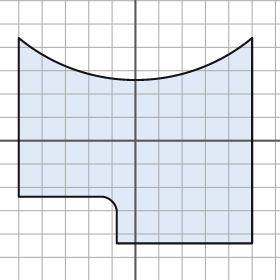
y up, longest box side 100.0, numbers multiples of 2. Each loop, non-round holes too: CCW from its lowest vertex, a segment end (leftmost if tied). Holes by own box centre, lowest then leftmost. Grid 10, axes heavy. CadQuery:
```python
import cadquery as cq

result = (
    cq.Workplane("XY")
    .moveTo(-8.0, -44.0)
    .lineTo(50.0, -44.0)
    .lineTo(50.0, 44.0)
    .threePointArc((0.0, 26.0), (-50.0, 44.0))
    .lineTo(-50.0, -24.0)
    .lineTo(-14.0, -24.0)
    .threePointArc((-10.0, -26.0), (-8.0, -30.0))
    .close()
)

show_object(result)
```